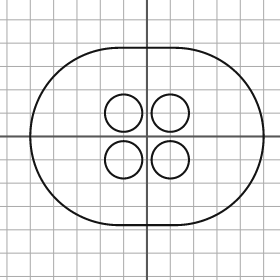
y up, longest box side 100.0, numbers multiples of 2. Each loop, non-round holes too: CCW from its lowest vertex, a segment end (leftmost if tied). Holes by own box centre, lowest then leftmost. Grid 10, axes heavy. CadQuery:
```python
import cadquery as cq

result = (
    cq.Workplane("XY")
    .moveTo(-12.0, -38.0)
    .lineTo(12.0, -38.0)
    .threePointArc((50.0, 0.0), (12.0, 38.0))
    .lineTo(-12.0, 38.0)
    .threePointArc((-50.0, 0.0), (-12.0, -38.0))
    .close()
    .moveTo(-10.0, -10.0)
    .circle(8.0)
    .moveTo(10.0, -10.0)
    .circle(8.0)
    .moveTo(-10.0, 10.0)
    .circle(8.0)
    .moveTo(10.0, 10.0)
    .circle(8.0)
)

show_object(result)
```